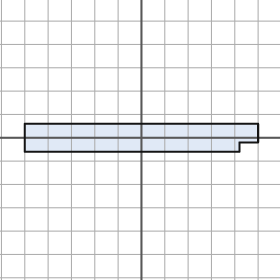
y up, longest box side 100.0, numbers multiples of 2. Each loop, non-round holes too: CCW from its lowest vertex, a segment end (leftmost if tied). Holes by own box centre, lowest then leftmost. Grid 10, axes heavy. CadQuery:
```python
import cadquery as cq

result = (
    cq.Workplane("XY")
    .moveTo(-50.0, -6.0)
    .lineTo(42.0, -6.0)
    .lineTo(42.0, -2.0)
    .lineTo(50.0, -2.0)
    .lineTo(50.0, 6.0)
    .lineTo(-50.0, 6.0)
    .close()
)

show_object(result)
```